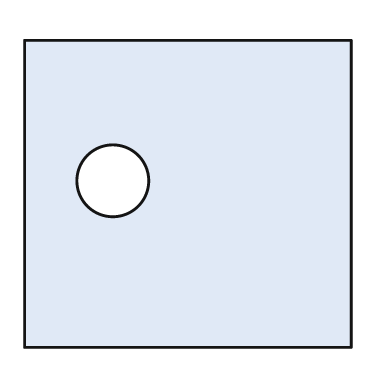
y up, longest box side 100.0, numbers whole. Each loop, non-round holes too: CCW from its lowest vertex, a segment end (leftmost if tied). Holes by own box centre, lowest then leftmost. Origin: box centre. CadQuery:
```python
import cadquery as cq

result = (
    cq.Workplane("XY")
    .moveTo(-50.0, -47.0)
    .lineTo(50.0, -47.0)
    .lineTo(50.0, 47.0)
    .lineTo(-50.0, 47.0)
    .close()
    .moveTo(-23.0, 4.0)
    .circle(11.0)
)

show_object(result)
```